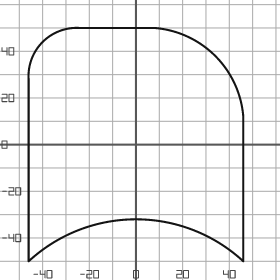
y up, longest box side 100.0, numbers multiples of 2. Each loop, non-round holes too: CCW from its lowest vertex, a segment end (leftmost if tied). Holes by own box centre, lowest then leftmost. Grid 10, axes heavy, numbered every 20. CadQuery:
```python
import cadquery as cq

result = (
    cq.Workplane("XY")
    .moveTo(-46.0, -50.0)
    .threePointArc((0.0, -32.0), (46.0, -50.0))
    .lineTo(46.0, 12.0)
    .threePointArc((34.0, 38.0), (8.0, 50.0))
    .lineTo(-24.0, 50.0)
    .threePointArc((-40.0, 44.0), (-46.0, 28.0))
    .close()
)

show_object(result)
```